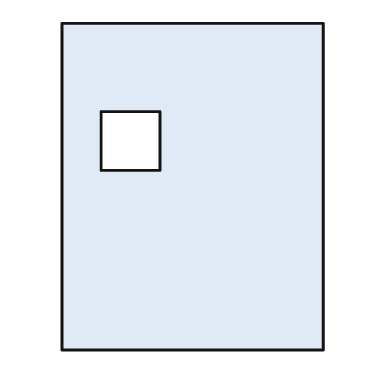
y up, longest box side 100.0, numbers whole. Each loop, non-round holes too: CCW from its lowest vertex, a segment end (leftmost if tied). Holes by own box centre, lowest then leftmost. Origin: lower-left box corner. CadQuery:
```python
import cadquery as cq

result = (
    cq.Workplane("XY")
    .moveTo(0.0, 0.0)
    .lineTo(80.0, 0.0)
    .lineTo(80.0, 100.0)
    .lineTo(0.0, 100.0)
    .close()
    .moveTo(12.0, 55.0)
    .lineTo(30.0, 55.0)
    .lineTo(30.0, 73.0)
    .lineTo(12.0, 73.0)
    .close()
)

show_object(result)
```